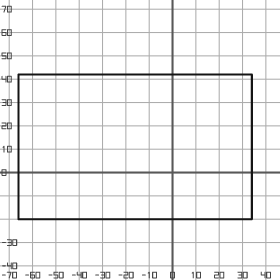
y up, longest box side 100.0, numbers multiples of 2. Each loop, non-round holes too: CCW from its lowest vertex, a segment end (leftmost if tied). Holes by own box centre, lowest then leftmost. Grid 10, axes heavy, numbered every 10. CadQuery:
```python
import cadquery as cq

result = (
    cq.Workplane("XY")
    .moveTo(-66.0, -20.0)
    .lineTo(34.0, -20.0)
    .lineTo(34.0, 42.0)
    .lineTo(-66.0, 42.0)
    .close()
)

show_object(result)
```